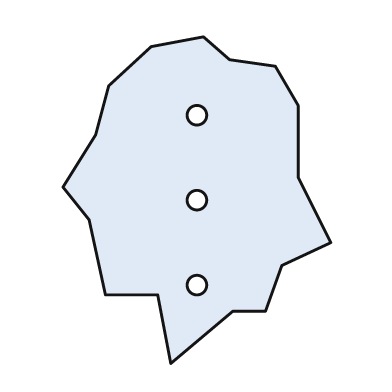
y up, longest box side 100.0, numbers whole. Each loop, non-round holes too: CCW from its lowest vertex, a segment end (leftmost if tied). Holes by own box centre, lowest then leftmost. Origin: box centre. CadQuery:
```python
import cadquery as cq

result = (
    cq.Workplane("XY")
    .moveTo(-8.0, -50.0)
    .lineTo(11.0, -34.0)
    .lineTo(21.0, -34.0)
    .lineTo(26.0, -20.0)
    .lineTo(41.0, -13.0)
    .lineTo(31.0, 7.0)
    .lineTo(31.0, 29.0)
    .lineTo(24.0, 41.0)
    .lineTo(10.0, 43.0)
    .lineTo(2.0, 50.0)
    .lineTo(-14.0, 47.0)
    .lineTo(-27.0, 35.0)
    .lineTo(-31.0, 20.0)
    .lineTo(-41.0, 4.0)
    .lineTo(-33.0, -6.0)
    .lineTo(-28.0, -29.0)
    .lineTo(-12.0, -29.0)
    .close()
    .moveTo(0.0, -26.0)
    .circle(3.0)
    .moveTo(0.0, 0.0)
    .circle(3.0)
    .moveTo(0.0, 26.0)
    .circle(3.0)
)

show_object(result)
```